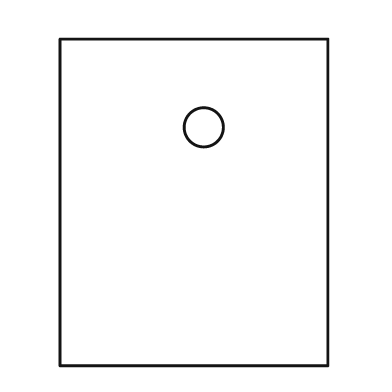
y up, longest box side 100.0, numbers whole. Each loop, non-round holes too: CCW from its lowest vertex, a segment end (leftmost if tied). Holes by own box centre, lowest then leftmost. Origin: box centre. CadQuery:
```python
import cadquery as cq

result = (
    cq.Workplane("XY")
    .moveTo(-41.0, -50.0)
    .lineTo(41.0, -50.0)
    .lineTo(41.0, 50.0)
    .lineTo(-41.0, 50.0)
    .close()
    .moveTo(3.0, 23.0)
    .circle(6.0)
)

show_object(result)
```